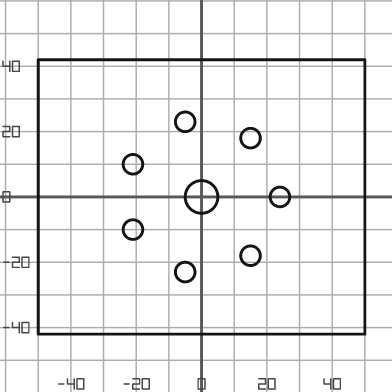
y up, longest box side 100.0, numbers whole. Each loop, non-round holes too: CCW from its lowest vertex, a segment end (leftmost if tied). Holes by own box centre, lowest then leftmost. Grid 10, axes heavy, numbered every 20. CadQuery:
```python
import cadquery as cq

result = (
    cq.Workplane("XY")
    .moveTo(-50.0, -42.0)
    .lineTo(50.0, -42.0)
    .lineTo(50.0, 42.0)
    .lineTo(-50.0, 42.0)
    .close()
    .moveTo(-5.0, -23.0)
    .circle(3.0)
    .moveTo(15.0, -18.0)
    .circle(3.0)
    .moveTo(-21.0, -10.0)
    .circle(3.0)
    .moveTo(0.0, 0.0)
    .circle(5.0)
    .moveTo(24.0, 0.0)
    .circle(3.0)
    .moveTo(-21.0, 10.0)
    .circle(3.0)
    .moveTo(15.0, 18.0)
    .circle(3.0)
    .moveTo(-5.0, 23.0)
    .circle(3.0)
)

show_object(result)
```